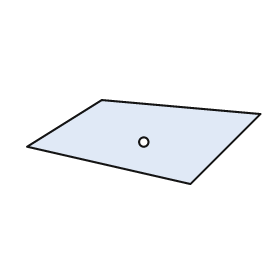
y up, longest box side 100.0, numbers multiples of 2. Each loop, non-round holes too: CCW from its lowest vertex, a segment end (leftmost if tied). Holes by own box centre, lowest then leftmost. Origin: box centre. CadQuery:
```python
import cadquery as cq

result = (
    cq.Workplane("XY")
    .moveTo(20.0, -18.0)
    .lineTo(50.0, 12.0)
    .lineTo(-18.0, 18.0)
    .lineTo(-50.0, -2.0)
    .close()
    .moveTo(0.0, 0.0)
    .circle(2.0)
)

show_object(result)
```